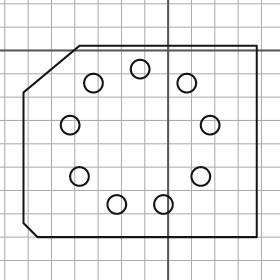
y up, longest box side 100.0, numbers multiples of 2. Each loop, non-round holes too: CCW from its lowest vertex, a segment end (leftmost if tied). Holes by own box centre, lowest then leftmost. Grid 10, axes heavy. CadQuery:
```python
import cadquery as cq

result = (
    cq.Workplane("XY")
    .moveTo(-56.0, -80.0)
    .lineTo(38.0, -80.0)
    .lineTo(38.0, 2.0)
    .lineTo(-38.0, 2.0)
    .lineTo(-62.0, -18.0)
    .lineTo(-62.0, -74.0)
    .close()
    .moveTo(-22.0, -66.0)
    .circle(4.0)
    .moveTo(-2.0, -66.0)
    .circle(4.0)
    .moveTo(-38.0, -54.0)
    .circle(4.0)
    .moveTo(14.0, -54.0)
    .circle(4.0)
    .moveTo(-42.0, -32.0)
    .circle(4.0)
    .moveTo(18.0, -32.0)
    .circle(4.0)
    .moveTo(-32.0, -14.0)
    .circle(4.0)
    .moveTo(8.0, -14.0)
    .circle(4.0)
    .moveTo(-12.0, -8.0)
    .circle(4.0)
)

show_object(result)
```